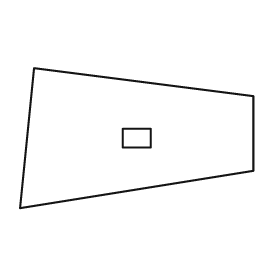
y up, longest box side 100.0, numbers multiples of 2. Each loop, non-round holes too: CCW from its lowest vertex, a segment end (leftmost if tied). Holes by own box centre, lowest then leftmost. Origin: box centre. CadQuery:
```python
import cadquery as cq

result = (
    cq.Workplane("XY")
    .moveTo(-50.0, -30.0)
    .lineTo(50.0, -14.0)
    .lineTo(50.0, 18.0)
    .lineTo(-44.0, 30.0)
    .close()
    .moveTo(-6.0, -4.0)
    .lineTo(6.0, -4.0)
    .lineTo(6.0, 4.0)
    .lineTo(-6.0, 4.0)
    .close()
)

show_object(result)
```